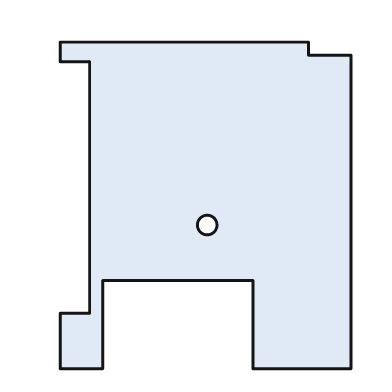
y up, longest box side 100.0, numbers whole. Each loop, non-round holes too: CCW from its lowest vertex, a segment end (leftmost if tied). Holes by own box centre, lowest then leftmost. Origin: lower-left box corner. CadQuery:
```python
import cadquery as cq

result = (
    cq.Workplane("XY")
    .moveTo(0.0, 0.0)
    .lineTo(13.0, 0.0)
    .lineTo(13.0, 27.0)
    .lineTo(59.0, 27.0)
    .lineTo(59.0, 0.0)
    .lineTo(89.0, 0.0)
    .lineTo(89.0, 96.0)
    .lineTo(76.0, 96.0)
    .lineTo(76.0, 100.0)
    .lineTo(0.0, 100.0)
    .lineTo(0.0, 94.0)
    .lineTo(9.0, 94.0)
    .lineTo(9.0, 17.0)
    .lineTo(0.0, 17.0)
    .close()
    .moveTo(45.0, 44.0)
    .circle(3.0)
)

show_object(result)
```